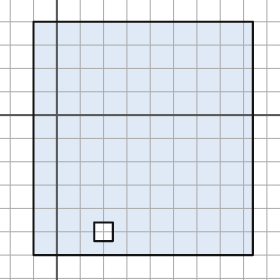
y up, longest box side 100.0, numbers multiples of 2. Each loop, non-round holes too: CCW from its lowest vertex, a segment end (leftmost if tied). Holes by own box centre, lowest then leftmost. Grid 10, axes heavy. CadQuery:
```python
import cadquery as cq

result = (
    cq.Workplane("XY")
    .moveTo(-10.0, -60.0)
    .lineTo(84.0, -60.0)
    .lineTo(84.0, 40.0)
    .lineTo(-10.0, 40.0)
    .close()
    .moveTo(16.0, -54.0)
    .lineTo(24.0, -54.0)
    .lineTo(24.0, -46.0)
    .lineTo(16.0, -46.0)
    .close()
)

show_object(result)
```